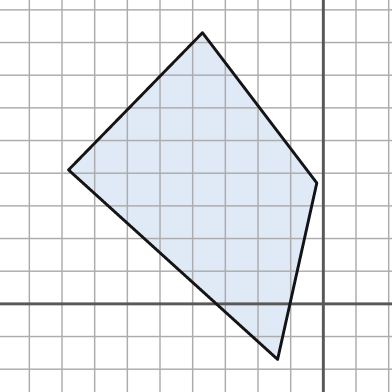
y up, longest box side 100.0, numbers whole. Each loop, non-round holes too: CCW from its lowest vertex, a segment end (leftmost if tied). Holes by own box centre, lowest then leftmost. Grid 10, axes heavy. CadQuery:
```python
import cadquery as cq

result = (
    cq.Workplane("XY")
    .moveTo(-14.0, -17.0)
    .lineTo(-2.0, 37.0)
    .lineTo(-37.0, 83.0)
    .lineTo(-78.0, 41.0)
    .close()
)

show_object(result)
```